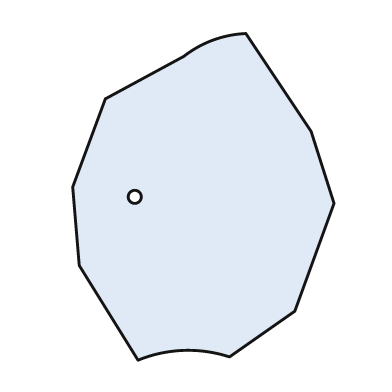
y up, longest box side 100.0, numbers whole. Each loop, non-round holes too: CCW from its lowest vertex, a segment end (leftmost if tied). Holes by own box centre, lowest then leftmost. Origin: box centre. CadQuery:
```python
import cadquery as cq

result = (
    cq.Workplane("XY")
    .moveTo(-20.0, -50.0)
    .threePointArc((-6.0, -47.0), (8.0, -49.0))
    .lineTo(28.0, -35.0)
    .lineTo(40.0, -2.0)
    .lineTo(33.0, 20.0)
    .lineTo(13.0, 50.0)
    .threePointArc((3.0, 48.0), (-6.0, 43.0))
    .lineTo(-30.0, 30.0)
    .lineTo(-40.0, 3.0)
    .lineTo(-38.0, -21.0)
    .close()
    .moveTo(-21.0, 0.0)
    .circle(2.0)
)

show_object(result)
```